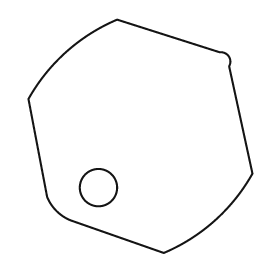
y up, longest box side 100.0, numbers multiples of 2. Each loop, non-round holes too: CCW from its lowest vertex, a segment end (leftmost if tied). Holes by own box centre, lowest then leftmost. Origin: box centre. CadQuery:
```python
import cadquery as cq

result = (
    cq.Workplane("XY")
    .moveTo(10.0, -50.0)
    .threePointArc((32.0, -36.0), (48.0, -16.0))
    .lineTo(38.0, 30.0)
    .threePointArc((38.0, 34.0), (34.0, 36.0))
    .lineTo(-10.0, 50.0)
    .threePointArc((-32.0, 36.0), (-48.0, 16.0))
    .lineTo(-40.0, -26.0)
    .threePointArc((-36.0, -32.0), (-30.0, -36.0))
    .close()
    .moveTo(-18.0, -22.0)
    .circle(8.0)
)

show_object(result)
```